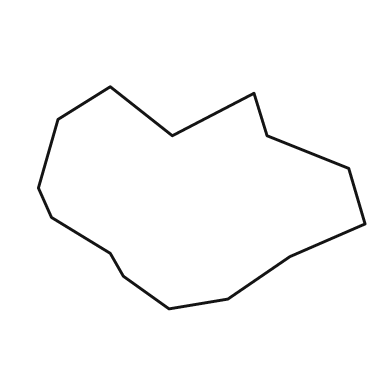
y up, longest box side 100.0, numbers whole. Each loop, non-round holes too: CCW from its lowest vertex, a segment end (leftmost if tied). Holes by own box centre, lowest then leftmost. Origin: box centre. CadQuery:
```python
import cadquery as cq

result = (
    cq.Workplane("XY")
    .moveTo(-10.0, -34.0)
    .lineTo(8.0, -31.0)
    .lineTo(27.0, -18.0)
    .lineTo(50.0, -8.0)
    .lineTo(45.0, 9.0)
    .lineTo(20.0, 19.0)
    .lineTo(16.0, 32.0)
    .lineTo(-9.0, 19.0)
    .lineTo(-28.0, 34.0)
    .lineTo(-44.0, 24.0)
    .lineTo(-50.0, 3.0)
    .lineTo(-46.0, -6.0)
    .lineTo(-28.0, -17.0)
    .lineTo(-24.0, -24.0)
    .close()
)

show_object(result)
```